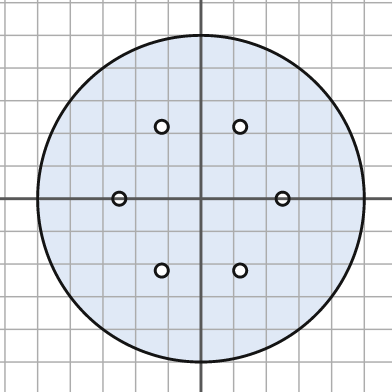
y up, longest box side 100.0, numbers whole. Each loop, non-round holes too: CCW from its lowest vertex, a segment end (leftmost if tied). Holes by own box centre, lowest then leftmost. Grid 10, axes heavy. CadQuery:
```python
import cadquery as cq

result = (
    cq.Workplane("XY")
    .moveTo(0.0, 0.0)
    .circle(50.0)
    .moveTo(-12.0, -22.0)
    .circle(2.0)
    .moveTo(12.0, -22.0)
    .circle(2.0)
    .moveTo(-25.0, 0.0)
    .circle(2.0)
    .moveTo(25.0, 0.0)
    .circle(2.0)
    .moveTo(-12.0, 22.0)
    .circle(2.0)
    .moveTo(12.0, 22.0)
    .circle(2.0)
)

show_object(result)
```